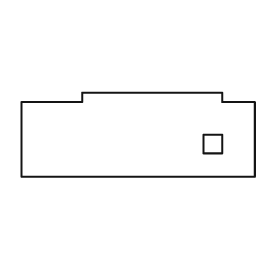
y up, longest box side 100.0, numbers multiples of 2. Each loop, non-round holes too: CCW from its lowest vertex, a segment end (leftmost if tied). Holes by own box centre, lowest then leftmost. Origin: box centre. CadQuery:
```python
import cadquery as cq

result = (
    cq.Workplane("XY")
    .moveTo(-50.0, -18.0)
    .lineTo(50.0, -18.0)
    .lineTo(50.0, 14.0)
    .lineTo(36.0, 14.0)
    .lineTo(36.0, 18.0)
    .lineTo(-24.0, 18.0)
    .lineTo(-24.0, 14.0)
    .lineTo(-50.0, 14.0)
    .close()
    .moveTo(28.0, -8.0)
    .lineTo(36.0, -8.0)
    .lineTo(36.0, 0.0)
    .lineTo(28.0, 0.0)
    .close()
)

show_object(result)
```